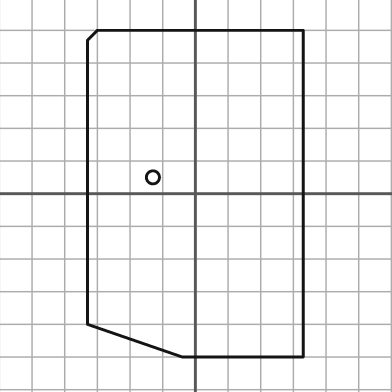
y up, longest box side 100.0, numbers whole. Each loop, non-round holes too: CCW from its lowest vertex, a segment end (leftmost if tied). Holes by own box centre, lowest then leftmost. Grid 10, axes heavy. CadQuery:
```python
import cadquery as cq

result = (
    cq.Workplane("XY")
    .moveTo(-4.0, -50.0)
    .lineTo(33.0, -50.0)
    .lineTo(33.0, 50.0)
    .lineTo(-30.0, 50.0)
    .lineTo(-33.0, 47.0)
    .lineTo(-33.0, -40.0)
    .close()
    .moveTo(-13.0, 5.0)
    .circle(2.0)
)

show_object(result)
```